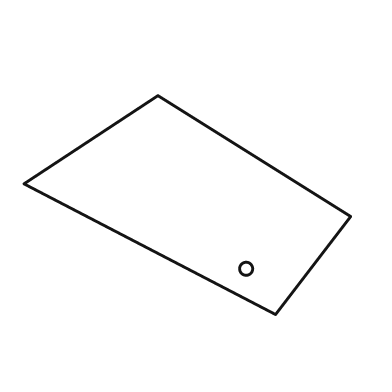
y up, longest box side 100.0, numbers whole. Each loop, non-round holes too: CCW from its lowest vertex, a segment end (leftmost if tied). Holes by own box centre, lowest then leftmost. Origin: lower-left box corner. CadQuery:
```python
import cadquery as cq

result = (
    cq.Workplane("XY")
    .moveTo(77.0, 0.0)
    .lineTo(100.0, 30.0)
    .lineTo(41.0, 67.0)
    .lineTo(0.0, 40.0)
    .close()
    .moveTo(68.0, 14.0)
    .circle(2.0)
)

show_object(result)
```